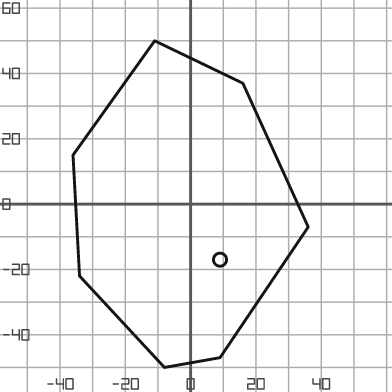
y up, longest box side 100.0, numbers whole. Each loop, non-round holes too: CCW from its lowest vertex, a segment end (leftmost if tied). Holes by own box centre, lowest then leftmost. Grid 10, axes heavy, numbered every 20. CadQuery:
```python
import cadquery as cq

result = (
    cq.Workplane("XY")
    .moveTo(-8.0, -50.0)
    .lineTo(9.0, -47.0)
    .lineTo(36.0, -7.0)
    .lineTo(16.0, 37.0)
    .lineTo(-11.0, 50.0)
    .lineTo(-36.0, 15.0)
    .lineTo(-34.0, -22.0)
    .close()
    .moveTo(9.0, -17.0)
    .circle(2.0)
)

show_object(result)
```